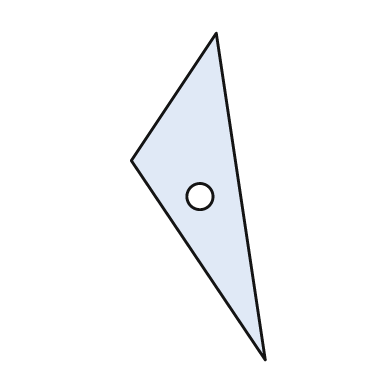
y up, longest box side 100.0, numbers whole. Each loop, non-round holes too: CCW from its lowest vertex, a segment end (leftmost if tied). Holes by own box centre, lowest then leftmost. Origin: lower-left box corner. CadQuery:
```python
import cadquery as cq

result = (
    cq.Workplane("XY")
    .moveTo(41.0, 0.0)
    .lineTo(26.0, 100.0)
    .lineTo(0.0, 61.0)
    .close()
    .moveTo(21.0, 50.0)
    .circle(4.0)
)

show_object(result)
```